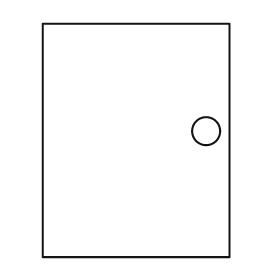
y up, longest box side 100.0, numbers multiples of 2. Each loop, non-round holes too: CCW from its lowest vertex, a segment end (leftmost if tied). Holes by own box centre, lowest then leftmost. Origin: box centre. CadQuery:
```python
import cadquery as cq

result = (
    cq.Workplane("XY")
    .moveTo(-40.0, -50.0)
    .lineTo(40.0, -50.0)
    .lineTo(40.0, 50.0)
    .lineTo(-40.0, 50.0)
    .close()
    .moveTo(30.0, 4.0)
    .circle(6.0)
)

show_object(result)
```